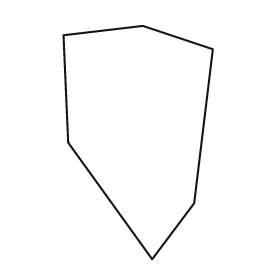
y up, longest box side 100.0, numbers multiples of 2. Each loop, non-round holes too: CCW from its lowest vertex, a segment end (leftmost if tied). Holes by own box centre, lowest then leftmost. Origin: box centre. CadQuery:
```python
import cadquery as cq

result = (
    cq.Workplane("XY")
    .moveTo(6.0, -50.0)
    .lineTo(24.0, -26.0)
    .lineTo(32.0, 40.0)
    .lineTo(2.0, 50.0)
    .lineTo(-32.0, 46.0)
    .lineTo(-30.0, 0.0)
    .close()
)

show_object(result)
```